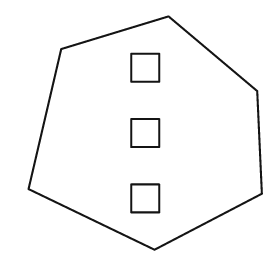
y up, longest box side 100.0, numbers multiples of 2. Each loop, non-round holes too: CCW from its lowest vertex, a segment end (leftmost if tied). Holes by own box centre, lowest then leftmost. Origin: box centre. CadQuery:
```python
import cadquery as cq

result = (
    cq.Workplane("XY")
    .moveTo(4.0, -50.0)
    .lineTo(50.0, -26.0)
    .lineTo(48.0, 18.0)
    .lineTo(10.0, 50.0)
    .lineTo(-36.0, 36.0)
    .lineTo(-50.0, -24.0)
    .close()
    .moveTo(-6.0, -34.0)
    .lineTo(6.0, -34.0)
    .lineTo(6.0, -22.0)
    .lineTo(-6.0, -22.0)
    .close()
    .moveTo(-6.0, -6.0)
    .lineTo(6.0, -6.0)
    .lineTo(6.0, 6.0)
    .lineTo(-6.0, 6.0)
    .close()
    .moveTo(-6.0, 22.0)
    .lineTo(6.0, 22.0)
    .lineTo(6.0, 34.0)
    .lineTo(-6.0, 34.0)
    .close()
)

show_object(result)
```